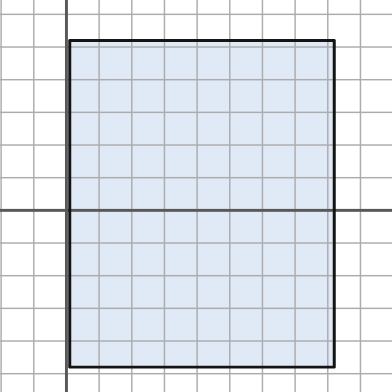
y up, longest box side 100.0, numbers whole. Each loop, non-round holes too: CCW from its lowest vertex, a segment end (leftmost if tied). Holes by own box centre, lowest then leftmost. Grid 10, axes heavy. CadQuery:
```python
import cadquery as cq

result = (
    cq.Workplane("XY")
    .moveTo(1.0, -48.0)
    .lineTo(82.0, -48.0)
    .lineTo(82.0, 52.0)
    .lineTo(1.0, 52.0)
    .close()
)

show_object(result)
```